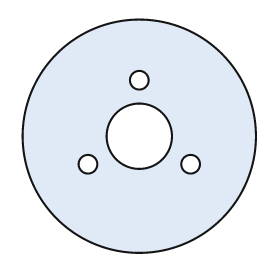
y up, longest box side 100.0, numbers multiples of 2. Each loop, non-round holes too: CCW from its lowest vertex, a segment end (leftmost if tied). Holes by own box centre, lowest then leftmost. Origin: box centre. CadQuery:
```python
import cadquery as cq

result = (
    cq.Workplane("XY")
    .moveTo(0.0, 0.0)
    .circle(50.0)
    .moveTo(-22.0, -12.0)
    .circle(4.0)
    .moveTo(22.0, -12.0)
    .circle(4.0)
    .moveTo(0.0, 0.0)
    .circle(14.0)
    .moveTo(0.0, 24.0)
    .circle(4.0)
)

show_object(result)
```